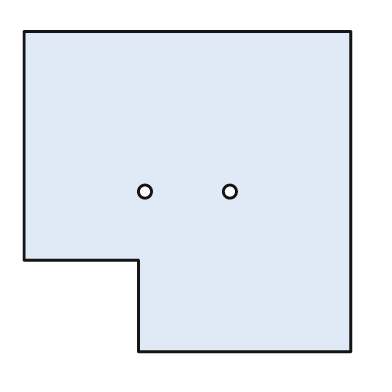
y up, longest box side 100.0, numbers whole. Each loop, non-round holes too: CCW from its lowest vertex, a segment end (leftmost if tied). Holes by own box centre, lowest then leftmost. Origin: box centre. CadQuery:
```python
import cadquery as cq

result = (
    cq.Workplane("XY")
    .moveTo(-15.0, -49.0)
    .lineTo(50.0, -49.0)
    .lineTo(50.0, 49.0)
    .lineTo(-50.0, 49.0)
    .lineTo(-50.0, -21.0)
    .lineTo(-15.0, -21.0)
    .close()
    .moveTo(-13.0, 0.0)
    .circle(2.0)
    .moveTo(13.0, 0.0)
    .circle(2.0)
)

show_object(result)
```